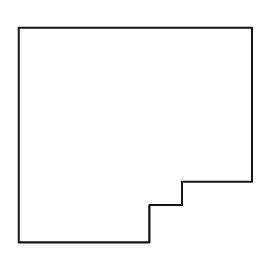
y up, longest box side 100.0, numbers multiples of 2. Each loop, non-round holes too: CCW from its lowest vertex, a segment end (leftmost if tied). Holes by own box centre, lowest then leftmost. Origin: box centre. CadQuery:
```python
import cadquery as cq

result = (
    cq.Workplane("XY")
    .moveTo(-50.0, -46.0)
    .lineTo(6.0, -46.0)
    .lineTo(6.0, -30.0)
    .lineTo(20.0, -30.0)
    .lineTo(20.0, -20.0)
    .lineTo(50.0, -20.0)
    .lineTo(50.0, 46.0)
    .lineTo(-50.0, 46.0)
    .close()
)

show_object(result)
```